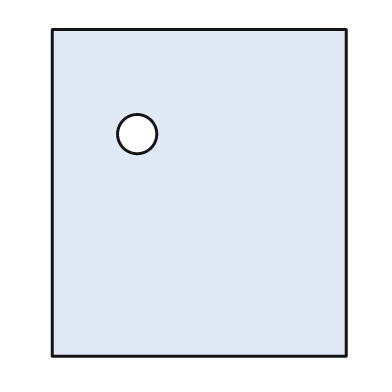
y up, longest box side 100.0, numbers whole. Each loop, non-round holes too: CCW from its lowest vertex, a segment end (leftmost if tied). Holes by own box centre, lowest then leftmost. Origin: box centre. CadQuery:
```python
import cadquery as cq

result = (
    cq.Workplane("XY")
    .moveTo(-45.0, -50.0)
    .lineTo(45.0, -50.0)
    .lineTo(45.0, 50.0)
    .lineTo(-45.0, 50.0)
    .close()
    .moveTo(-19.0, 18.0)
    .circle(6.0)
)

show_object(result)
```